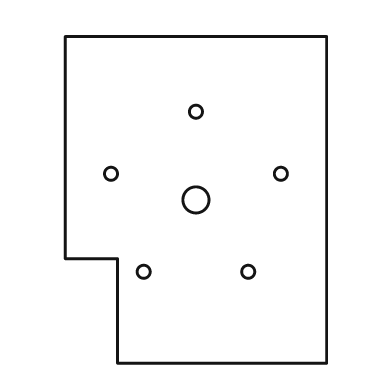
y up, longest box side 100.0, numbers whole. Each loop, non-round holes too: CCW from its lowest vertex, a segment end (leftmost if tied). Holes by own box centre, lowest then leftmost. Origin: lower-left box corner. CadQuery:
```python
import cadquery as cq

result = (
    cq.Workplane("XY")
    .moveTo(16.0, 0.0)
    .lineTo(80.0, 0.0)
    .lineTo(80.0, 100.0)
    .lineTo(0.0, 100.0)
    .lineTo(0.0, 32.0)
    .lineTo(16.0, 32.0)
    .close()
    .moveTo(24.0, 28.0)
    .circle(2.0)
    .moveTo(56.0, 28.0)
    .circle(2.0)
    .moveTo(40.0, 50.0)
    .circle(4.0)
    .moveTo(14.0, 58.0)
    .circle(2.0)
    .moveTo(66.0, 58.0)
    .circle(2.0)
    .moveTo(40.0, 77.0)
    .circle(2.0)
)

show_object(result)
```